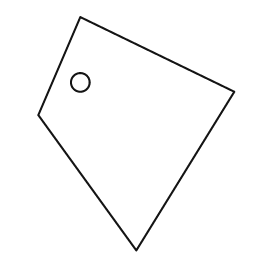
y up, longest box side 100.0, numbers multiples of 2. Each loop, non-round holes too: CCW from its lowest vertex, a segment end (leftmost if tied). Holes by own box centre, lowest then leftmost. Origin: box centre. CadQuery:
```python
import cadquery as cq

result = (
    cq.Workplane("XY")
    .moveTo(0.0, -50.0)
    .lineTo(42.0, 18.0)
    .lineTo(-24.0, 50.0)
    .lineTo(-42.0, 8.0)
    .close()
    .moveTo(-24.0, 22.0)
    .circle(4.0)
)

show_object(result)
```